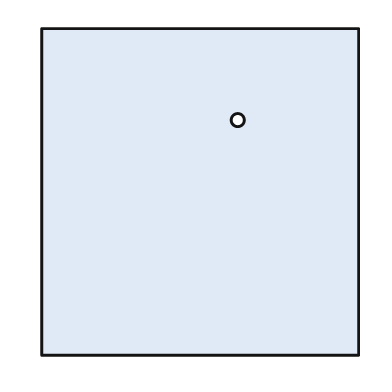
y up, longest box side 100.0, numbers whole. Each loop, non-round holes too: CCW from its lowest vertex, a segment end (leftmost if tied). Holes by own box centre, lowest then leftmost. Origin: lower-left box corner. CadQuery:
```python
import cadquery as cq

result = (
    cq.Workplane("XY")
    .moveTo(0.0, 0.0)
    .lineTo(97.0, 0.0)
    .lineTo(97.0, 100.0)
    .lineTo(0.0, 100.0)
    .close()
    .moveTo(60.0, 72.0)
    .circle(2.0)
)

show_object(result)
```